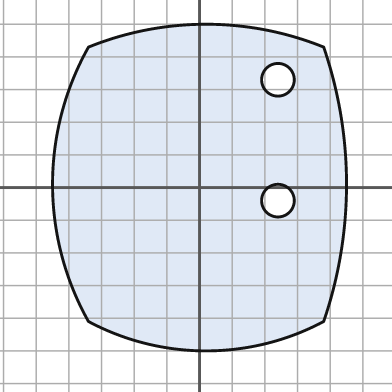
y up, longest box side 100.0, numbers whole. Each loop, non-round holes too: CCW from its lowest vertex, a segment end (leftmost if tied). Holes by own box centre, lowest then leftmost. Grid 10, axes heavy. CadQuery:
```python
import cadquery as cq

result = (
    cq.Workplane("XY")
    .moveTo(-34.0, -41.0)
    .threePointArc((2.0, -50.0), (38.0, -41.0))
    .threePointArc((45.0, 1.0), (38.0, 43.0))
    .threePointArc((2.0, 50.0), (-34.0, 43.0))
    .threePointArc((-45.0, 1.0), (-34.0, -41.0))
    .close()
    .moveTo(24.0, -4.0)
    .circle(5.0)
    .moveTo(24.0, 33.0)
    .circle(5.0)
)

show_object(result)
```